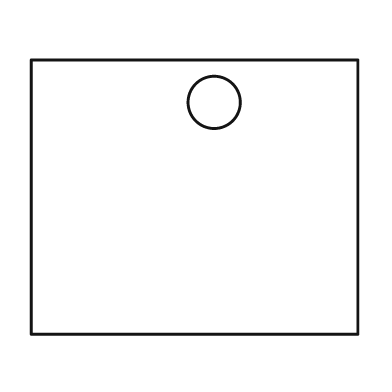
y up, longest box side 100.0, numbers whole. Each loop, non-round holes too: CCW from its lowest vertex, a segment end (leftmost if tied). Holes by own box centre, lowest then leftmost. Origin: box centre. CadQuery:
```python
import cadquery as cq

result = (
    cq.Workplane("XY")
    .moveTo(-50.0, -42.0)
    .lineTo(50.0, -42.0)
    .lineTo(50.0, 42.0)
    .lineTo(-50.0, 42.0)
    .close()
    .moveTo(6.0, 29.0)
    .circle(8.0)
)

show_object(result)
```